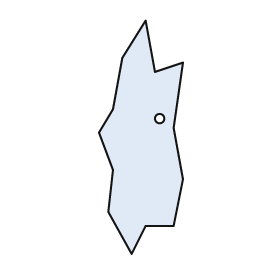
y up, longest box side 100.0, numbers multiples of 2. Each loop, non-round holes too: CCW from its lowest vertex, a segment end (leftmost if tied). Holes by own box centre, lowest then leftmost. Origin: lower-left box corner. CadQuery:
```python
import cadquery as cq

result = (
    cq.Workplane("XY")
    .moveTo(14.0, 0.0)
    .lineTo(20.0, 12.0)
    .lineTo(32.0, 12.0)
    .lineTo(36.0, 32.0)
    .lineTo(32.0, 54.0)
    .lineTo(36.0, 82.0)
    .lineTo(24.0, 78.0)
    .lineTo(20.0, 100.0)
    .lineTo(10.0, 84.0)
    .lineTo(6.0, 62.0)
    .lineTo(0.0, 52.0)
    .lineTo(6.0, 36.0)
    .lineTo(4.0, 18.0)
    .close()
    .moveTo(26.0, 58.0)
    .circle(2.0)
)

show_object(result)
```